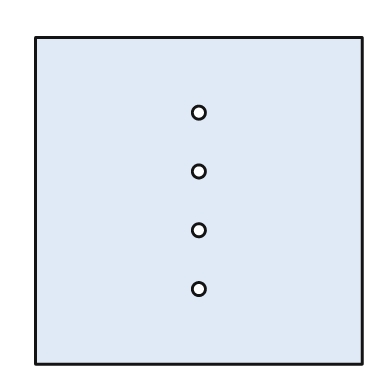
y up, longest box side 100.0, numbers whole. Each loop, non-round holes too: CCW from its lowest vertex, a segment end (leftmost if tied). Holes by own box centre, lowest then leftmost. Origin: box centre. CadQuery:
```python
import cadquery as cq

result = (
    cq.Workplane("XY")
    .moveTo(-50.0, -50.0)
    .lineTo(50.0, -50.0)
    .lineTo(50.0, 50.0)
    .lineTo(-50.0, 50.0)
    .close()
    .moveTo(0.0, -27.0)
    .circle(2.0)
    .moveTo(0.0, -9.0)
    .circle(2.0)
    .moveTo(0.0, 9.0)
    .circle(2.0)
    .moveTo(0.0, 27.0)
    .circle(2.0)
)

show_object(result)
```